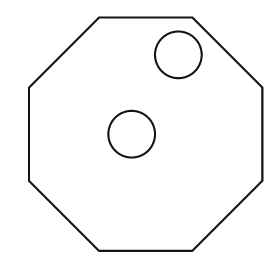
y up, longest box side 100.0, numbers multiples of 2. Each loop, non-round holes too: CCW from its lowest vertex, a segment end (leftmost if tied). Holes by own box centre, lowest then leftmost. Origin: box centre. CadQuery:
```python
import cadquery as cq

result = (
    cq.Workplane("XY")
    .moveTo(-20.0, -50.0)
    .lineTo(20.0, -50.0)
    .lineTo(50.0, -20.0)
    .lineTo(50.0, 20.0)
    .lineTo(20.0, 50.0)
    .lineTo(-20.0, 50.0)
    .lineTo(-50.0, 20.0)
    .lineTo(-50.0, -20.0)
    .close()
    .moveTo(-6.0, 0.0)
    .circle(10.0)
    .moveTo(14.0, 34.0)
    .circle(10.0)
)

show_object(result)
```